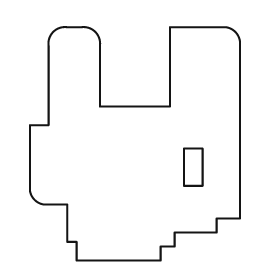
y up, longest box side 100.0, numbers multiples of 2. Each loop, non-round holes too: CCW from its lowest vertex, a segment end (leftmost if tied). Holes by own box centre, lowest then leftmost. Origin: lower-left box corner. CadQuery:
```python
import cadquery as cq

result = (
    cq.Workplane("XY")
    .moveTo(20.0, 0.0)
    .lineTo(56.0, 0.0)
    .lineTo(56.0, 6.0)
    .lineTo(62.0, 6.0)
    .lineTo(62.0, 12.0)
    .lineTo(80.0, 12.0)
    .lineTo(80.0, 18.0)
    .lineTo(90.0, 18.0)
    .lineTo(90.0, 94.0)
    .threePointArc((88.0, 98.0), (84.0, 100.0))
    .lineTo(60.0, 100.0)
    .lineTo(60.0, 66.0)
    .lineTo(30.0, 66.0)
    .lineTo(30.0, 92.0)
    .threePointArc((28.0, 98.0), (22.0, 100.0))
    .lineTo(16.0, 100.0)
    .threePointArc((10.0, 98.0), (8.0, 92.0))
    .lineTo(8.0, 58.0)
    .lineTo(0.0, 58.0)
    .lineTo(0.0, 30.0)
    .threePointArc((2.0, 26.0), (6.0, 24.0))
    .lineTo(16.0, 24.0)
    .lineTo(16.0, 8.0)
    .lineTo(20.0, 8.0)
    .close()
    .moveTo(66.0, 32.0)
    .lineTo(74.0, 32.0)
    .lineTo(74.0, 48.0)
    .lineTo(66.0, 48.0)
    .close()
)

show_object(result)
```